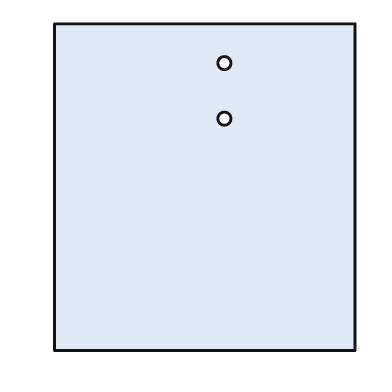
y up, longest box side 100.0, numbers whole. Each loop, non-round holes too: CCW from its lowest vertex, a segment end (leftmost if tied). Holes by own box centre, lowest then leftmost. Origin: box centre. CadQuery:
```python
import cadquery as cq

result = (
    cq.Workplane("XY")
    .moveTo(-46.0, -50.0)
    .lineTo(46.0, -50.0)
    .lineTo(46.0, 50.0)
    .lineTo(-46.0, 50.0)
    .close()
    .moveTo(6.0, 21.0)
    .circle(2.0)
    .moveTo(6.0, 38.0)
    .circle(2.0)
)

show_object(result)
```